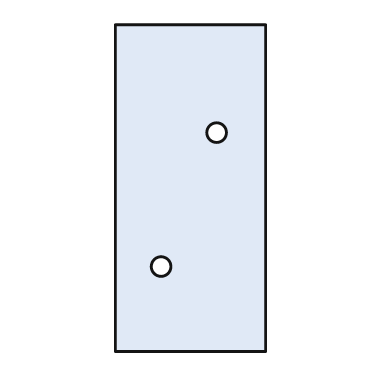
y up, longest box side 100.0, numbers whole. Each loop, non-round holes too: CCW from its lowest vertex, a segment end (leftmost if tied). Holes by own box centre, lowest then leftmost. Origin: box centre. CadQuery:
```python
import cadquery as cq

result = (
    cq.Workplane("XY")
    .moveTo(-23.0, -50.0)
    .lineTo(23.0, -50.0)
    .lineTo(23.0, 50.0)
    .lineTo(-23.0, 50.0)
    .close()
    .moveTo(-9.0, -24.0)
    .circle(3.0)
    .moveTo(8.0, 17.0)
    .circle(3.0)
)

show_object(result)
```